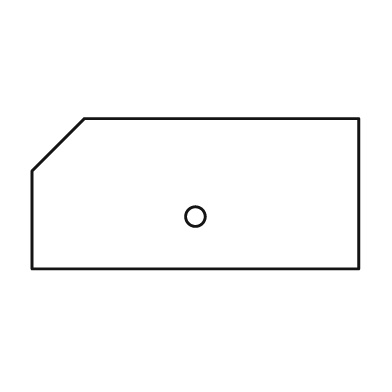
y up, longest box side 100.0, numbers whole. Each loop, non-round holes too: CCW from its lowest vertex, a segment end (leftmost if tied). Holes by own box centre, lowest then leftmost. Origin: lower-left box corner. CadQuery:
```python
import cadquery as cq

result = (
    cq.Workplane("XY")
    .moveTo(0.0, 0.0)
    .lineTo(100.0, 0.0)
    .lineTo(100.0, 46.0)
    .lineTo(16.0, 46.0)
    .lineTo(0.0, 30.0)
    .close()
    .moveTo(50.0, 16.0)
    .circle(3.0)
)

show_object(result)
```